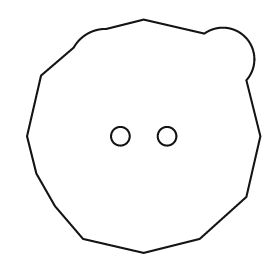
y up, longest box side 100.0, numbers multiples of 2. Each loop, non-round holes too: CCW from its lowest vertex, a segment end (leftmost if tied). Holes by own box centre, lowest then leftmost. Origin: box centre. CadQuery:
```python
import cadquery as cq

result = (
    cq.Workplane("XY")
    .moveTo(0.0, -50.0)
    .lineTo(24.0, -44.0)
    .lineTo(44.0, -26.0)
    .lineTo(50.0, 0.0)
    .lineTo(44.0, 24.0)
    .threePointArc((44.0, 42.0), (26.0, 44.0))
    .lineTo(0.0, 50.0)
    .lineTo(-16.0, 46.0)
    .threePointArc((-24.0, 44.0), (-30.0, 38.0))
    .lineTo(-44.0, 26.0)
    .lineTo(-50.0, 0.0)
    .lineTo(-46.0, -16.0)
    .lineTo(-38.0, -30.0)
    .lineTo(-26.0, -44.0)
    .close()
    .moveTo(-10.0, 0.0)
    .circle(4.0)
    .moveTo(10.0, 0.0)
    .circle(4.0)
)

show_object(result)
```